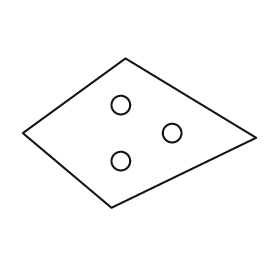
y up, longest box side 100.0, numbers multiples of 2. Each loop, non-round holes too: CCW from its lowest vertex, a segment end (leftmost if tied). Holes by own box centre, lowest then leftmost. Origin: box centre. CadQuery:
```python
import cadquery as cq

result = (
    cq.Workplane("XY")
    .moveTo(-12.0, -32.0)
    .lineTo(50.0, -2.0)
    .lineTo(-6.0, 32.0)
    .lineTo(-50.0, 0.0)
    .close()
    .moveTo(-8.0, -12.0)
    .circle(4.0)
    .moveTo(14.0, 0.0)
    .circle(4.0)
    .moveTo(-8.0, 12.0)
    .circle(4.0)
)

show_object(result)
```